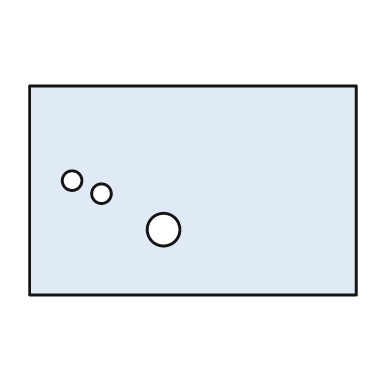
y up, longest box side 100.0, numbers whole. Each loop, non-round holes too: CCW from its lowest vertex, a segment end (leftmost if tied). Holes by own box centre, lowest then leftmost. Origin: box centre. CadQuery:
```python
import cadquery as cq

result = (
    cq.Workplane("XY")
    .moveTo(-50.0, -32.0)
    .lineTo(50.0, -32.0)
    .lineTo(50.0, 32.0)
    .lineTo(-50.0, 32.0)
    .close()
    .moveTo(-9.0, -12.0)
    .circle(5.0)
    .moveTo(-28.0, -1.0)
    .circle(3.0)
    .moveTo(-37.0, 3.0)
    .circle(3.0)
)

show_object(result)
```